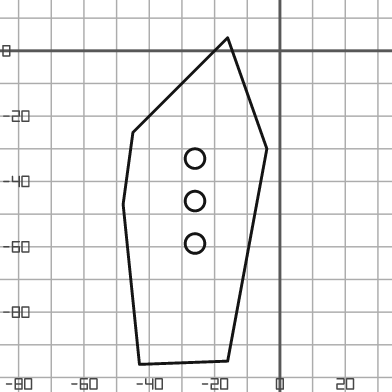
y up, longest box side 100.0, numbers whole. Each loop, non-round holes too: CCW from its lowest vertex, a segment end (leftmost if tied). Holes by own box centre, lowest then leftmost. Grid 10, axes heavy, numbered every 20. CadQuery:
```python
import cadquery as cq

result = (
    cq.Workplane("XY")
    .moveTo(-43.0, -96.0)
    .lineTo(-16.0, -95.0)
    .lineTo(-4.0, -30.0)
    .lineTo(-16.0, 4.0)
    .lineTo(-45.0, -25.0)
    .lineTo(-48.0, -47.0)
    .close()
    .moveTo(-26.0, -59.0)
    .circle(3.0)
    .moveTo(-26.0, -46.0)
    .circle(3.0)
    .moveTo(-26.0, -33.0)
    .circle(3.0)
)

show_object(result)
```